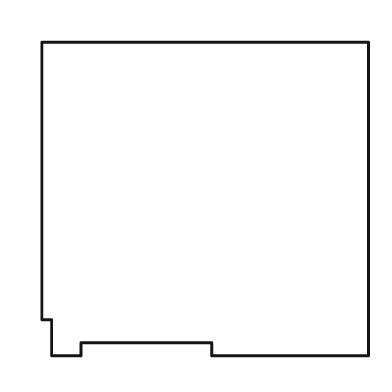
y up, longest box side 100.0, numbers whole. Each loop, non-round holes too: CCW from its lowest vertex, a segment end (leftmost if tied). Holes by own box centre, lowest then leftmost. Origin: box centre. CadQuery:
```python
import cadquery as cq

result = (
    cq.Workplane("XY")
    .moveTo(-47.0, -48.0)
    .lineTo(-38.0, -48.0)
    .lineTo(-38.0, -44.0)
    .lineTo(2.0, -44.0)
    .lineTo(2.0, -48.0)
    .lineTo(50.0, -48.0)
    .lineTo(50.0, 48.0)
    .lineTo(-50.0, 48.0)
    .lineTo(-50.0, -37.0)
    .lineTo(-47.0, -37.0)
    .close()
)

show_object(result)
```